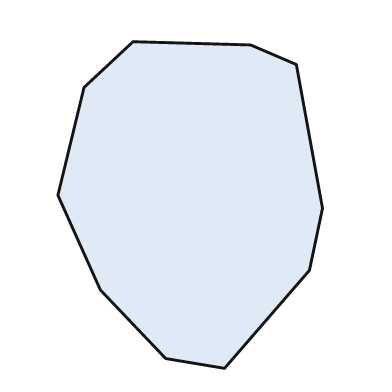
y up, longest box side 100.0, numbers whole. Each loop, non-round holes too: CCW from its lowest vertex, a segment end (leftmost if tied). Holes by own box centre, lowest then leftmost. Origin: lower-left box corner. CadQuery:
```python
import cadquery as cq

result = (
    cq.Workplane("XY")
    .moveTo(51.0, 0.0)
    .lineTo(77.0, 30.0)
    .lineTo(81.0, 49.0)
    .lineTo(73.0, 93.0)
    .lineTo(59.0, 99.0)
    .lineTo(23.0, 100.0)
    .lineTo(8.0, 86.0)
    .lineTo(0.0, 53.0)
    .lineTo(13.0, 24.0)
    .lineTo(33.0, 3.0)
    .close()
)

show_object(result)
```